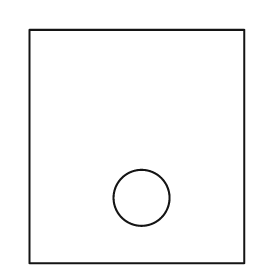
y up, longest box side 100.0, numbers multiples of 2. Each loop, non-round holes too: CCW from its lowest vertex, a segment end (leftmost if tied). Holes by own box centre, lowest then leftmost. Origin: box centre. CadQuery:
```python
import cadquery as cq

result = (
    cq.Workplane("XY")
    .moveTo(-46.0, -50.0)
    .lineTo(46.0, -50.0)
    .lineTo(46.0, 50.0)
    .lineTo(-46.0, 50.0)
    .close()
    .moveTo(2.0, -22.0)
    .circle(12.0)
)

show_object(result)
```